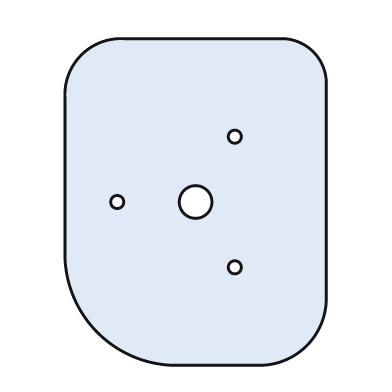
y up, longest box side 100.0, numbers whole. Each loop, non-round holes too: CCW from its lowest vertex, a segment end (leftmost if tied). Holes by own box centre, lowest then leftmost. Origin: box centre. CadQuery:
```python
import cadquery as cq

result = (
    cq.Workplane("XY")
    .moveTo(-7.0, -50.0)
    .lineTo(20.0, -50.0)
    .threePointArc((34.0, -44.0), (40.0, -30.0))
    .lineTo(40.0, 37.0)
    .threePointArc((36.0, 46.0), (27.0, 50.0))
    .lineTo(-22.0, 50.0)
    .threePointArc((-35.0, 45.0), (-40.0, 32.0))
    .lineTo(-40.0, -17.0)
    .threePointArc((-30.0, -40.0), (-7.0, -50.0))
    .close()
    .moveTo(12.0, -20.0)
    .circle(2.0)
    .moveTo(-24.0, 0.0)
    .circle(2.0)
    .moveTo(0.0, 0.0)
    .circle(5.0)
    .moveTo(12.0, 20.0)
    .circle(2.0)
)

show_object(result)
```